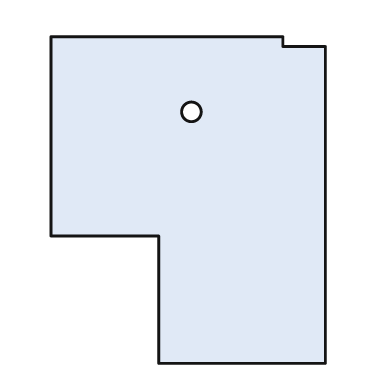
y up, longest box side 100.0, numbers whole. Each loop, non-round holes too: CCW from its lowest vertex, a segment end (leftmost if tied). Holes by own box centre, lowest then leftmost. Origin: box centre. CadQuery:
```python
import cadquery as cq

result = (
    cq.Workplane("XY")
    .moveTo(-9.0, -50.0)
    .lineTo(42.0, -50.0)
    .lineTo(42.0, 47.0)
    .lineTo(29.0, 47.0)
    .lineTo(29.0, 50.0)
    .lineTo(-42.0, 50.0)
    .lineTo(-42.0, -11.0)
    .lineTo(-9.0, -11.0)
    .close()
    .moveTo(1.0, 27.0)
    .circle(3.0)
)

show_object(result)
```